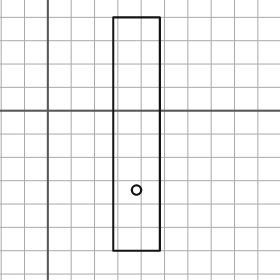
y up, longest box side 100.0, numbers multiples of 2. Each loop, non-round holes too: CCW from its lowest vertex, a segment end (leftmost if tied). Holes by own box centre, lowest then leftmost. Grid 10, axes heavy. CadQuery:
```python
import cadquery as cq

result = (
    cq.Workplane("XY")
    .moveTo(28.0, -60.0)
    .lineTo(48.0, -60.0)
    .lineTo(48.0, 40.0)
    .lineTo(28.0, 40.0)
    .close()
    .moveTo(38.0, -34.0)
    .circle(2.0)
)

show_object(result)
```